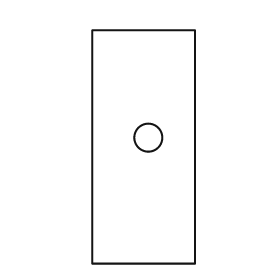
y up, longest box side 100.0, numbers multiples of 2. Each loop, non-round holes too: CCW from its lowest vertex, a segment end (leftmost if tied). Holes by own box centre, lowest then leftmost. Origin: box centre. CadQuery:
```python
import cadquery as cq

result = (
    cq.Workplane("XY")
    .moveTo(-22.0, -50.0)
    .lineTo(22.0, -50.0)
    .lineTo(22.0, 50.0)
    .lineTo(-22.0, 50.0)
    .close()
    .moveTo(2.0, 4.0)
    .circle(6.0)
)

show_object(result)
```